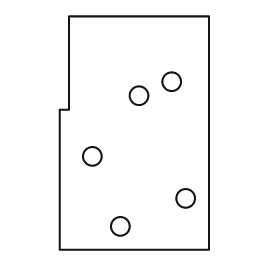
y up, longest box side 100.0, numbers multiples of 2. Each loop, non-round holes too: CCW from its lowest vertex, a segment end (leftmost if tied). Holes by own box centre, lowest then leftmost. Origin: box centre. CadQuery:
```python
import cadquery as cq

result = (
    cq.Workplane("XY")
    .moveTo(-32.0, -50.0)
    .lineTo(32.0, -50.0)
    .lineTo(32.0, 50.0)
    .lineTo(-28.0, 50.0)
    .lineTo(-28.0, 10.0)
    .lineTo(-32.0, 10.0)
    .close()
    .moveTo(-6.0, -40.0)
    .circle(4.0)
    .moveTo(22.0, -28.0)
    .circle(4.0)
    .moveTo(-18.0, -10.0)
    .circle(4.0)
    .moveTo(2.0, 16.0)
    .circle(4.0)
    .moveTo(16.0, 22.0)
    .circle(4.0)
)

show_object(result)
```